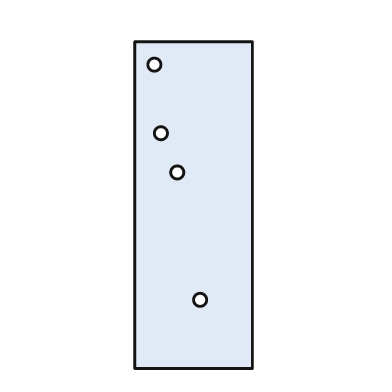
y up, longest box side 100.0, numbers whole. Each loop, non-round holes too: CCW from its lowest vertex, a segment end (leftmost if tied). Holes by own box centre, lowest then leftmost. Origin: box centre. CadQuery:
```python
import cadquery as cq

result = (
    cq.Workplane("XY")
    .moveTo(-18.0, -50.0)
    .lineTo(18.0, -50.0)
    .lineTo(18.0, 50.0)
    .lineTo(-18.0, 50.0)
    .close()
    .moveTo(2.0, -29.0)
    .circle(2.0)
    .moveTo(-5.0, 10.0)
    .circle(2.0)
    .moveTo(-10.0, 22.0)
    .circle(2.0)
    .moveTo(-12.0, 43.0)
    .circle(2.0)
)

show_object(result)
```